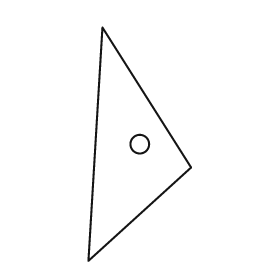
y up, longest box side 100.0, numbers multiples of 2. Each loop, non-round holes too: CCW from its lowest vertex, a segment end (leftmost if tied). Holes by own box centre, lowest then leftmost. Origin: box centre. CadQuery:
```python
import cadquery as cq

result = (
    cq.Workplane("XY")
    .moveTo(-22.0, -50.0)
    .lineTo(22.0, -10.0)
    .lineTo(-16.0, 50.0)
    .close()
    .moveTo(0.0, 0.0)
    .circle(4.0)
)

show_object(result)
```